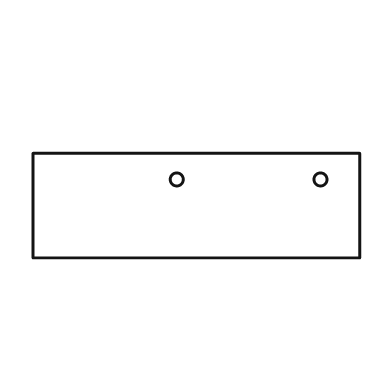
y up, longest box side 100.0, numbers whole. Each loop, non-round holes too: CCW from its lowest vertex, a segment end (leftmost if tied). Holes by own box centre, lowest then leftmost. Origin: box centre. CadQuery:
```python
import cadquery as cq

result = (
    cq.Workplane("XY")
    .moveTo(-50.0, -16.0)
    .lineTo(50.0, -16.0)
    .lineTo(50.0, 16.0)
    .lineTo(-50.0, 16.0)
    .close()
    .moveTo(-6.0, 8.0)
    .circle(2.0)
    .moveTo(38.0, 8.0)
    .circle(2.0)
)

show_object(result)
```